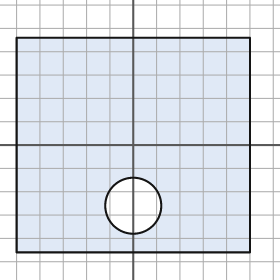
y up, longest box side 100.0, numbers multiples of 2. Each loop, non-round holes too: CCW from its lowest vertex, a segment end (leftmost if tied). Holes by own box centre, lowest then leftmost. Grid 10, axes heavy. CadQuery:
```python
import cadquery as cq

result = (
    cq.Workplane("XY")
    .moveTo(-50.0, -46.0)
    .lineTo(50.0, -46.0)
    .lineTo(50.0, 46.0)
    .lineTo(-50.0, 46.0)
    .close()
    .moveTo(0.0, -26.0)
    .circle(12.0)
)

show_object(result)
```